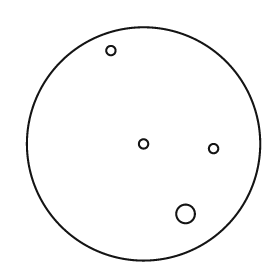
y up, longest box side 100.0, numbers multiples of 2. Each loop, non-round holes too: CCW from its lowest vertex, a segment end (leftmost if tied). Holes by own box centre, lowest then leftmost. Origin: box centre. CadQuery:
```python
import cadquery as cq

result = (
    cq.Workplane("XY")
    .moveTo(0.0, 0.0)
    .circle(50.0)
    .moveTo(18.0, -30.0)
    .circle(4.0)
    .moveTo(30.0, -2.0)
    .circle(2.0)
    .moveTo(0.0, 0.0)
    .circle(2.0)
    .moveTo(-14.0, 40.0)
    .circle(2.0)
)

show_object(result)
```